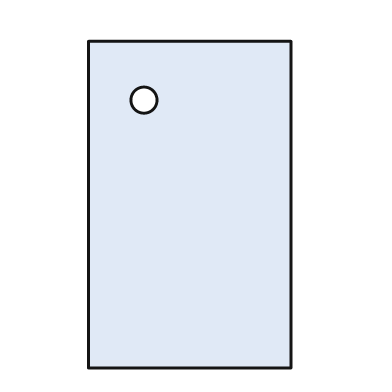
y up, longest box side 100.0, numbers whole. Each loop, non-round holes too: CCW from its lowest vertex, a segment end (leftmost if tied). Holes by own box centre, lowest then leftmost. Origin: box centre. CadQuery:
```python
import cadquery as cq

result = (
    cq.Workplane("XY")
    .moveTo(-31.0, -50.0)
    .lineTo(31.0, -50.0)
    .lineTo(31.0, 50.0)
    .lineTo(-31.0, 50.0)
    .close()
    .moveTo(-14.0, 32.0)
    .circle(4.0)
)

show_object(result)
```